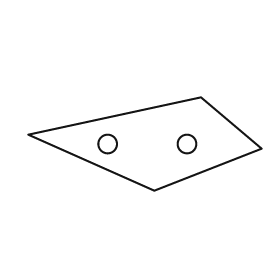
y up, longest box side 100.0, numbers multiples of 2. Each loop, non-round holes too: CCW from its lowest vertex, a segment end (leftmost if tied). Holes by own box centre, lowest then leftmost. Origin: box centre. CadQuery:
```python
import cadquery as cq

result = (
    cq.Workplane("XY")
    .moveTo(4.0, -20.0)
    .lineTo(50.0, -2.0)
    .lineTo(24.0, 20.0)
    .lineTo(-50.0, 4.0)
    .close()
    .moveTo(-16.0, 0.0)
    .circle(4.0)
    .moveTo(18.0, 0.0)
    .circle(4.0)
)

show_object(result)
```